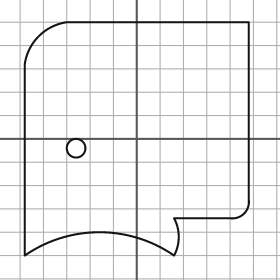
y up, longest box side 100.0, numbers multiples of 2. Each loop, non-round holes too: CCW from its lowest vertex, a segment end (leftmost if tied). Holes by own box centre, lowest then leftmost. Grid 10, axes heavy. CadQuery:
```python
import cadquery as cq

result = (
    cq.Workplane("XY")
    .moveTo(-48.0, -50.0)
    .threePointArc((-16.0, -40.0), (16.0, -50.0))
    .threePointArc((18.0, -42.0), (16.0, -34.0))
    .lineTo(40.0, -34.0)
    .threePointArc((46.0, -32.0), (48.0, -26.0))
    .lineTo(48.0, 50.0)
    .lineTo(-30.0, 50.0)
    .threePointArc((-42.0, 44.0), (-48.0, 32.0))
    .close()
    .moveTo(-26.0, -4.0)
    .circle(4.0)
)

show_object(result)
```